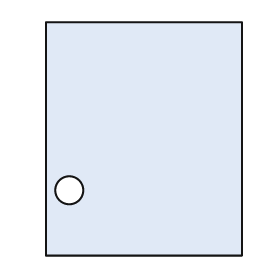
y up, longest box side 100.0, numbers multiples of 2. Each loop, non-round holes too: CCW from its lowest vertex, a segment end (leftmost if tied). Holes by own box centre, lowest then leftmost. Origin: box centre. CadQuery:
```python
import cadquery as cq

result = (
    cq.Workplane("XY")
    .moveTo(-42.0, -50.0)
    .lineTo(42.0, -50.0)
    .lineTo(42.0, 50.0)
    .lineTo(-42.0, 50.0)
    .close()
    .moveTo(-32.0, -22.0)
    .circle(6.0)
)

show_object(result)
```